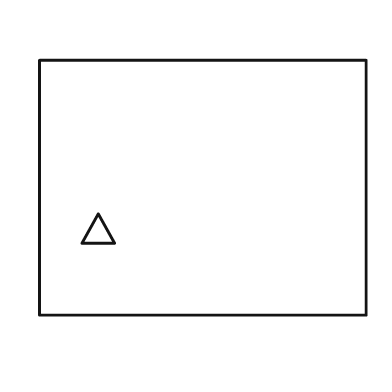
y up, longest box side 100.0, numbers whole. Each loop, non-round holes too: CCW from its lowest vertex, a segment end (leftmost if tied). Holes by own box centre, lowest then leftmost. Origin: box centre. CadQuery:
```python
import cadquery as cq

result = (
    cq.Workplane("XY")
    .moveTo(-50.0, -39.0)
    .lineTo(50.0, -39.0)
    .lineTo(50.0, 39.0)
    .lineTo(-50.0, 39.0)
    .close()
    .moveTo(-37.0, -17.0)
    .lineTo(-27.0, -17.0)
    .lineTo(-32.0, -8.0)
    .close()
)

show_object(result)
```